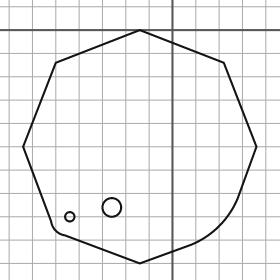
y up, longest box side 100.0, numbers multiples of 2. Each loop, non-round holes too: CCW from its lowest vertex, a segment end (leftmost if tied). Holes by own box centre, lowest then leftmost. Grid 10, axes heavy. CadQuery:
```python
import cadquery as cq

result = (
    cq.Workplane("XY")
    .moveTo(-14.0, -100.0)
    .lineTo(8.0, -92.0)
    .threePointArc((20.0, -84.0), (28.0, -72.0))
    .lineTo(36.0, -50.0)
    .lineTo(22.0, -14.0)
    .lineTo(-14.0, 0.0)
    .lineTo(-50.0, -14.0)
    .lineTo(-64.0, -50.0)
    .lineTo(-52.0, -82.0)
    .threePointArc((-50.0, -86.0), (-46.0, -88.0))
    .close()
    .moveTo(-44.0, -80.0)
    .circle(2.0)
    .moveTo(-26.0, -76.0)
    .circle(4.0)
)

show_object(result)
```